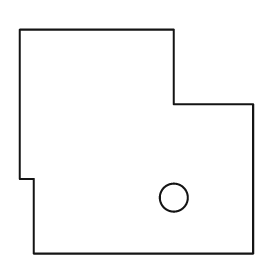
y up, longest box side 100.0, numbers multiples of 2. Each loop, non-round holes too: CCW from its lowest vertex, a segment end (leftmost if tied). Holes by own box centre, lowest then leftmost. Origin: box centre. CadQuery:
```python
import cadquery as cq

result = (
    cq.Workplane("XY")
    .moveTo(-44.0, -48.0)
    .lineTo(50.0, -48.0)
    .lineTo(50.0, 16.0)
    .lineTo(16.0, 16.0)
    .lineTo(16.0, 48.0)
    .lineTo(-50.0, 48.0)
    .lineTo(-50.0, -16.0)
    .lineTo(-44.0, -16.0)
    .close()
    .moveTo(16.0, -24.0)
    .circle(6.0)
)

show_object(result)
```